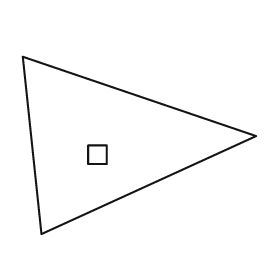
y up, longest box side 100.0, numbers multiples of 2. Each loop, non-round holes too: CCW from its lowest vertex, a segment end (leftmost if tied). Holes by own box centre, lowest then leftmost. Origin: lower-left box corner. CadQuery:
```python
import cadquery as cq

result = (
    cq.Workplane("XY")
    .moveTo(8.0, 0.0)
    .lineTo(100.0, 42.0)
    .lineTo(0.0, 76.0)
    .close()
    .moveTo(28.0, 30.0)
    .lineTo(36.0, 30.0)
    .lineTo(36.0, 38.0)
    .lineTo(28.0, 38.0)
    .close()
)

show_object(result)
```